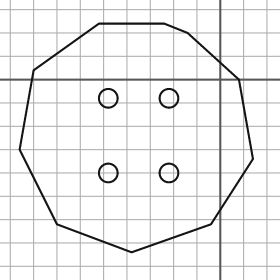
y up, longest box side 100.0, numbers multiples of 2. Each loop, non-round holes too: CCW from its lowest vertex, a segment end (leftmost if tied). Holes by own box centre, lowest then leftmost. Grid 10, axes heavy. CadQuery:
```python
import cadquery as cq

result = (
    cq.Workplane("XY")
    .moveTo(-38.0, -74.0)
    .lineTo(-4.0, -62.0)
    .lineTo(14.0, -34.0)
    .lineTo(8.0, 0.0)
    .lineTo(-14.0, 20.0)
    .lineTo(-24.0, 24.0)
    .lineTo(-52.0, 24.0)
    .lineTo(-80.0, 4.0)
    .lineTo(-86.0, -30.0)
    .lineTo(-70.0, -62.0)
    .close()
    .moveTo(-48.0, -40.0)
    .circle(4.0)
    .moveTo(-22.0, -40.0)
    .circle(4.0)
    .moveTo(-48.0, -8.0)
    .circle(4.0)
    .moveTo(-22.0, -8.0)
    .circle(4.0)
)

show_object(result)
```